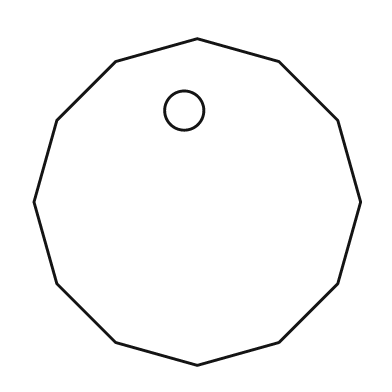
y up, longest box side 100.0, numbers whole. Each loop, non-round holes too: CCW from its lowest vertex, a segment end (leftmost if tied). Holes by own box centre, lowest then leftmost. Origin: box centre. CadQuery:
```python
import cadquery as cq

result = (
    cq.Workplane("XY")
    .moveTo(0.0, -50.0)
    .lineTo(25.0, -43.0)
    .lineTo(43.0, -25.0)
    .lineTo(50.0, 0.0)
    .lineTo(43.0, 25.0)
    .lineTo(25.0, 43.0)
    .lineTo(0.0, 50.0)
    .lineTo(-25.0, 43.0)
    .lineTo(-43.0, 25.0)
    .lineTo(-50.0, 0.0)
    .lineTo(-43.0, -25.0)
    .lineTo(-25.0, -43.0)
    .close()
    .moveTo(-4.0, 28.0)
    .circle(6.0)
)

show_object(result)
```